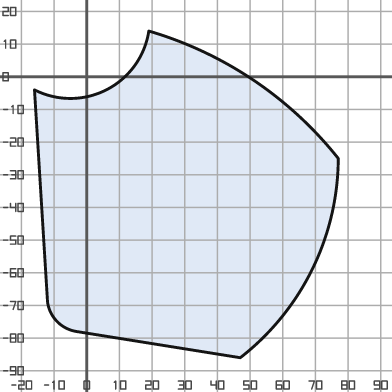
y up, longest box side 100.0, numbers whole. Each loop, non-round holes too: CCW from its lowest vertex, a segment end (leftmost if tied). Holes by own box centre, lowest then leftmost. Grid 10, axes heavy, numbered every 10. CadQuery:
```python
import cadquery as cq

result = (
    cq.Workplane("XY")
    .moveTo(47.0, -86.0)
    .threePointArc((69.0, -59.0), (77.0, -25.0))
    .threePointArc((51.0, -1.0), (19.0, 14.0))
    .threePointArc((6.0, -4.0), (-16.0, -4.0))
    .lineTo(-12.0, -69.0)
    .threePointArc((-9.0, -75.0), (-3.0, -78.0))
    .close()
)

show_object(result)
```